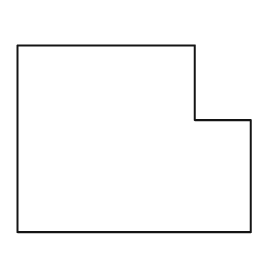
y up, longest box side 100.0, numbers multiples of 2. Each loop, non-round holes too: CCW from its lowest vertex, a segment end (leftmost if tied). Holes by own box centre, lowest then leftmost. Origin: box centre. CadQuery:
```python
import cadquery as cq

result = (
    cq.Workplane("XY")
    .moveTo(-50.0, -40.0)
    .lineTo(50.0, -40.0)
    .lineTo(50.0, 8.0)
    .lineTo(26.0, 8.0)
    .lineTo(26.0, 40.0)
    .lineTo(-50.0, 40.0)
    .close()
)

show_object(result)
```